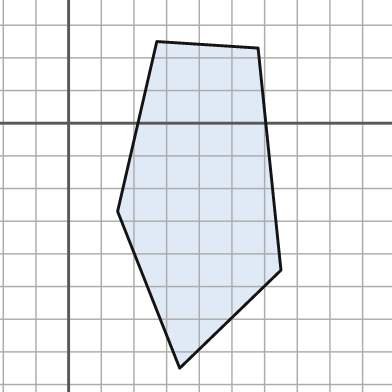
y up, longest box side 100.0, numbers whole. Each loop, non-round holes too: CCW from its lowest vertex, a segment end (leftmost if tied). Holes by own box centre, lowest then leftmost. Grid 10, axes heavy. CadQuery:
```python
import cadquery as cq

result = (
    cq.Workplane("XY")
    .moveTo(34.0, -75.0)
    .lineTo(65.0, -45.0)
    .lineTo(58.0, 23.0)
    .lineTo(27.0, 25.0)
    .lineTo(15.0, -27.0)
    .close()
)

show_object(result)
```